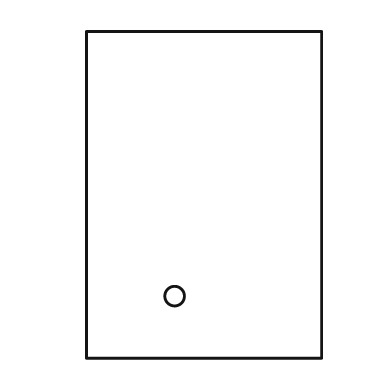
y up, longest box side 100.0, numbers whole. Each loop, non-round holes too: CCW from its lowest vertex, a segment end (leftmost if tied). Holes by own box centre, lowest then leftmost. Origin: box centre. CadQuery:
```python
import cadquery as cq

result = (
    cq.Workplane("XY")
    .moveTo(-36.0, -50.0)
    .lineTo(36.0, -50.0)
    .lineTo(36.0, 50.0)
    .lineTo(-36.0, 50.0)
    .close()
    .moveTo(-9.0, -31.0)
    .circle(3.0)
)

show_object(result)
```